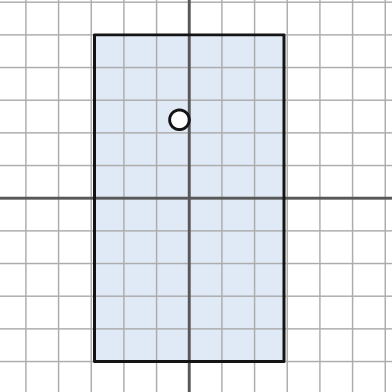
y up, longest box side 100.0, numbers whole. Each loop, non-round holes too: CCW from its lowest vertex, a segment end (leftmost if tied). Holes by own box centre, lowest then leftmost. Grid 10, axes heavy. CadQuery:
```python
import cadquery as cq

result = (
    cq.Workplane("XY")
    .moveTo(-29.0, -50.0)
    .lineTo(29.0, -50.0)
    .lineTo(29.0, 50.0)
    .lineTo(-29.0, 50.0)
    .close()
    .moveTo(-3.0, 24.0)
    .circle(3.0)
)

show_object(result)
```